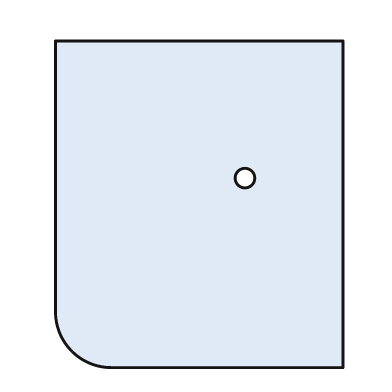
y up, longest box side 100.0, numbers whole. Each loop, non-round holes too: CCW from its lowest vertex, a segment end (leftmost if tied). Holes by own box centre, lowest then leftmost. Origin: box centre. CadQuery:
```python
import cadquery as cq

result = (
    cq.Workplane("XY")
    .moveTo(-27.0, -50.0)
    .lineTo(44.0, -50.0)
    .lineTo(44.0, 50.0)
    .lineTo(-44.0, 50.0)
    .lineTo(-44.0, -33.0)
    .threePointArc((-39.0, -45.0), (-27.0, -50.0))
    .close()
    .moveTo(14.0, 8.0)
    .circle(3.0)
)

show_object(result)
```